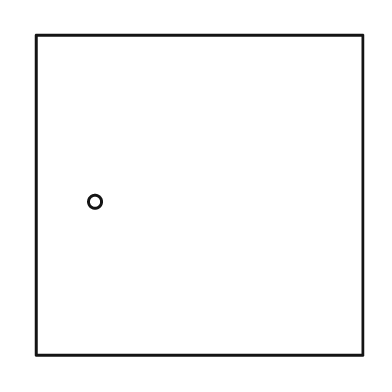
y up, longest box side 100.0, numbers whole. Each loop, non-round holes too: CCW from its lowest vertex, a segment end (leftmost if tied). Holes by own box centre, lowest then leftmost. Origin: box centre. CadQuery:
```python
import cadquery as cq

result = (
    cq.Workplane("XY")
    .moveTo(-50.0, -49.0)
    .lineTo(50.0, -49.0)
    .lineTo(50.0, 49.0)
    .lineTo(-50.0, 49.0)
    .close()
    .moveTo(-32.0, -2.0)
    .circle(2.0)
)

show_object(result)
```